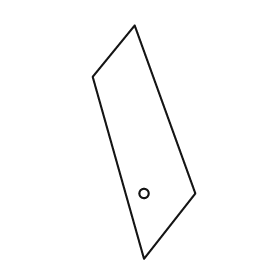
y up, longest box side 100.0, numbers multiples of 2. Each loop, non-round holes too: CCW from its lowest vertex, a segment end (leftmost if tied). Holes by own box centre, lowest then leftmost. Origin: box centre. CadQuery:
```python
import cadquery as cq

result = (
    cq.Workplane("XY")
    .moveTo(0.0, -50.0)
    .lineTo(22.0, -22.0)
    .lineTo(-4.0, 50.0)
    .lineTo(-22.0, 28.0)
    .close()
    .moveTo(0.0, -22.0)
    .circle(2.0)
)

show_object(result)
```